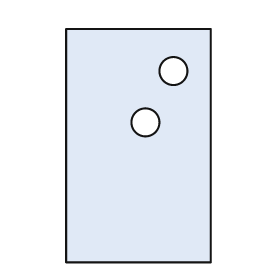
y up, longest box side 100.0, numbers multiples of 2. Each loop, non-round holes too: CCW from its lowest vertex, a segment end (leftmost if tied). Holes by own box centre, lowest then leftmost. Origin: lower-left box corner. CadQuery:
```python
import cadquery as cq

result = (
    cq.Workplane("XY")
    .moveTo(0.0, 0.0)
    .lineTo(62.0, 0.0)
    .lineTo(62.0, 100.0)
    .lineTo(0.0, 100.0)
    .close()
    .moveTo(34.0, 60.0)
    .circle(6.0)
    .moveTo(46.0, 82.0)
    .circle(6.0)
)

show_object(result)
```